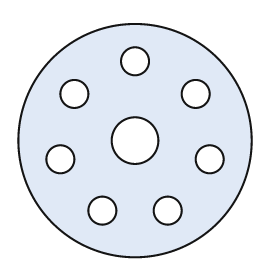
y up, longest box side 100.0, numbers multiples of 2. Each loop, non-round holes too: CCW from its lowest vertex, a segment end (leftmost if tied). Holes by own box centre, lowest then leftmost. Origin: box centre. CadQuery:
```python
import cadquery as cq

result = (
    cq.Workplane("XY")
    .moveTo(0.0, 0.0)
    .circle(50.0)
    .moveTo(-14.0, -30.0)
    .circle(6.0)
    .moveTo(14.0, -30.0)
    .circle(6.0)
    .moveTo(-32.0, -8.0)
    .circle(6.0)
    .moveTo(32.0, -8.0)
    .circle(6.0)
    .moveTo(0.0, 0.0)
    .circle(10.0)
    .moveTo(-26.0, 20.0)
    .circle(6.0)
    .moveTo(26.0, 20.0)
    .circle(6.0)
    .moveTo(0.0, 34.0)
    .circle(6.0)
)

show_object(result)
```